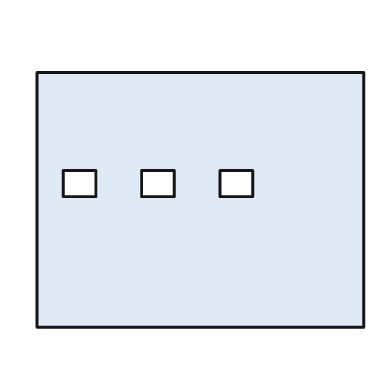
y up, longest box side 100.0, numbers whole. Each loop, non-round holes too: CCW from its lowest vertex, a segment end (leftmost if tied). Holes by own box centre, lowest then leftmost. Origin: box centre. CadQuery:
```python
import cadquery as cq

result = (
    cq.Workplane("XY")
    .moveTo(-50.0, -39.0)
    .lineTo(50.0, -39.0)
    .lineTo(50.0, 39.0)
    .lineTo(-50.0, 39.0)
    .close()
    .moveTo(-42.0, 1.0)
    .lineTo(-32.0, 1.0)
    .lineTo(-32.0, 9.0)
    .lineTo(-42.0, 9.0)
    .close()
    .moveTo(-18.0, 1.0)
    .lineTo(-8.0, 1.0)
    .lineTo(-8.0, 9.0)
    .lineTo(-18.0, 9.0)
    .close()
    .moveTo(6.0, 1.0)
    .lineTo(16.0, 1.0)
    .lineTo(16.0, 9.0)
    .lineTo(6.0, 9.0)
    .close()
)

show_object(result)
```